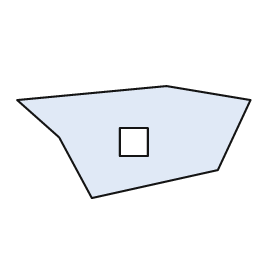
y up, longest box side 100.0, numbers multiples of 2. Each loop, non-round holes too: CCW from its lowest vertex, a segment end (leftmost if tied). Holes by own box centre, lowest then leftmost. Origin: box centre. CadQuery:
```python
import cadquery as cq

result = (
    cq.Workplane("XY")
    .moveTo(-18.0, -24.0)
    .lineTo(36.0, -12.0)
    .lineTo(50.0, 18.0)
    .lineTo(14.0, 24.0)
    .lineTo(-50.0, 18.0)
    .lineTo(-32.0, 2.0)
    .close()
    .moveTo(-6.0, -6.0)
    .lineTo(6.0, -6.0)
    .lineTo(6.0, 6.0)
    .lineTo(-6.0, 6.0)
    .close()
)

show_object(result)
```